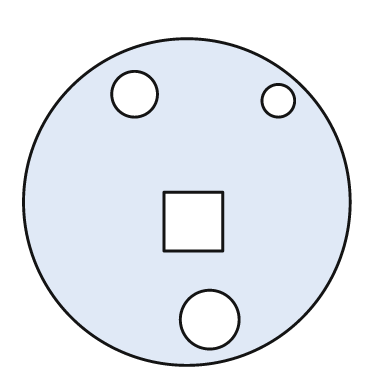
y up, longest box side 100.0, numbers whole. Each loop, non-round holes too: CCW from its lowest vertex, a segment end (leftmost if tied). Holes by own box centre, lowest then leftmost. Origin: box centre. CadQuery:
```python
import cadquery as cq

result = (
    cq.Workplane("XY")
    .moveTo(0.0, 0.0)
    .circle(50.0)
    .moveTo(7.0, -36.0)
    .circle(9.0)
    .moveTo(-7.0, -15.0)
    .lineTo(11.0, -15.0)
    .lineTo(11.0, 3.0)
    .lineTo(-7.0, 3.0)
    .close()
    .moveTo(28.0, 31.0)
    .circle(5.0)
    .moveTo(-16.0, 33.0)
    .circle(7.0)
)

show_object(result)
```